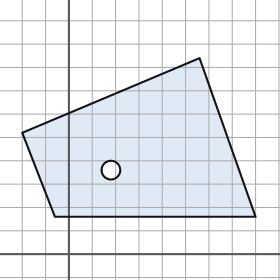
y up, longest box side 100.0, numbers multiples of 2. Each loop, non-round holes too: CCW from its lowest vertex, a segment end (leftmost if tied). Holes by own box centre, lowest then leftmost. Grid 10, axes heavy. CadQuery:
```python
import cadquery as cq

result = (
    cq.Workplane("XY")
    .moveTo(-6.0, 16.0)
    .lineTo(80.0, 16.0)
    .lineTo(56.0, 84.0)
    .lineTo(-20.0, 52.0)
    .close()
    .moveTo(18.0, 36.0)
    .circle(4.0)
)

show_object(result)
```